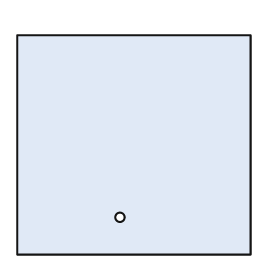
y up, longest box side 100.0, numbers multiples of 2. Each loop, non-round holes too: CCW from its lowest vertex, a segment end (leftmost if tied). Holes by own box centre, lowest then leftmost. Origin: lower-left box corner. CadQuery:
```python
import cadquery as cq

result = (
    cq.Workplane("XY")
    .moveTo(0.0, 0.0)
    .lineTo(100.0, 0.0)
    .lineTo(100.0, 94.0)
    .lineTo(0.0, 94.0)
    .close()
    .moveTo(44.0, 16.0)
    .circle(2.0)
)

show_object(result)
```